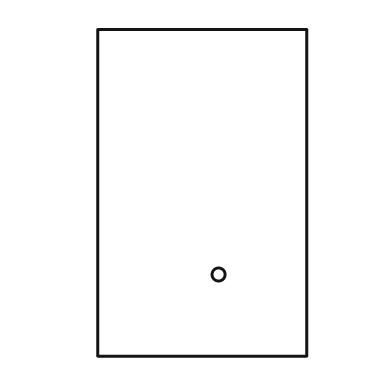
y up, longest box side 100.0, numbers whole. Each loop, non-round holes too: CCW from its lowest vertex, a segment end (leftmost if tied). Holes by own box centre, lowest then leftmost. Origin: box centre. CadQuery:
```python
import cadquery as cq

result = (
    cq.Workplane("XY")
    .moveTo(-32.0, -50.0)
    .lineTo(32.0, -50.0)
    .lineTo(32.0, 50.0)
    .lineTo(-32.0, 50.0)
    .close()
    .moveTo(5.0, -25.0)
    .circle(2.0)
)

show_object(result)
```